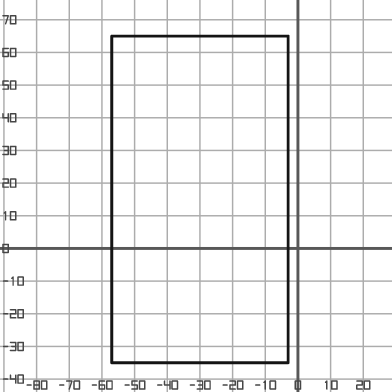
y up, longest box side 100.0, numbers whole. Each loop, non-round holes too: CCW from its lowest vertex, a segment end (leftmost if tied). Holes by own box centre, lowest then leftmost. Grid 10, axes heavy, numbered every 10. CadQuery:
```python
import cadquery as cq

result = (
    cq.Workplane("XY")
    .moveTo(-57.0, -35.0)
    .lineTo(-3.0, -35.0)
    .lineTo(-3.0, 65.0)
    .lineTo(-57.0, 65.0)
    .close()
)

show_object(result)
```